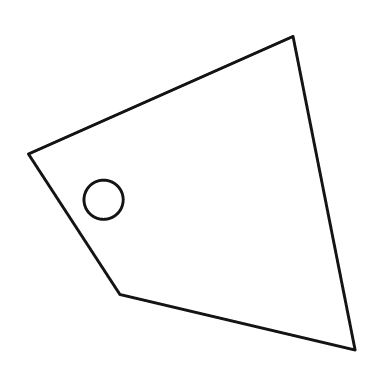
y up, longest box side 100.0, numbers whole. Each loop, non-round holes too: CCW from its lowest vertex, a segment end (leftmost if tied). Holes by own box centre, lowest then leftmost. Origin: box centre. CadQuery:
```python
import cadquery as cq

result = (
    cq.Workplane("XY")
    .moveTo(50.0, -48.0)
    .lineTo(31.0, 48.0)
    .lineTo(-50.0, 12.0)
    .lineTo(-22.0, -31.0)
    .close()
    .moveTo(-27.0, -2.0)
    .circle(6.0)
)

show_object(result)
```